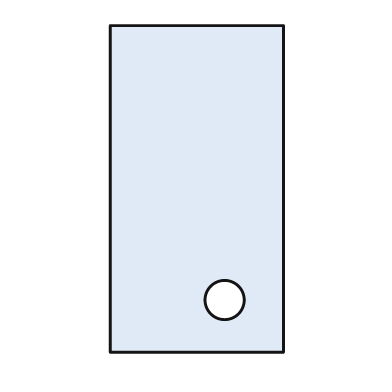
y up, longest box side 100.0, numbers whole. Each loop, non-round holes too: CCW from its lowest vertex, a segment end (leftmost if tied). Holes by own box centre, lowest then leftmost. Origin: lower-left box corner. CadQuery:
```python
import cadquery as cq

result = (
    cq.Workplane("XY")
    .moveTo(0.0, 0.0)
    .lineTo(53.0, 0.0)
    .lineTo(53.0, 100.0)
    .lineTo(0.0, 100.0)
    .close()
    .moveTo(35.0, 16.0)
    .circle(6.0)
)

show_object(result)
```